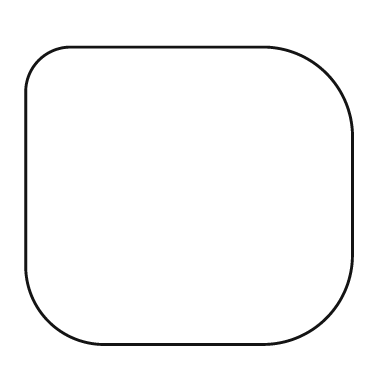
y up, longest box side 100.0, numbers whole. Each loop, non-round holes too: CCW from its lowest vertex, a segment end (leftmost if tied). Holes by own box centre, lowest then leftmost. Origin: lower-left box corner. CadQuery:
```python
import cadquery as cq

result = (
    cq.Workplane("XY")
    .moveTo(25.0, 0.0)
    .lineTo(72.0, 0.0)
    .threePointArc((92.0, 8.0), (100.0, 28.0))
    .lineTo(100.0, 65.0)
    .threePointArc((92.0, 83.0), (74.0, 91.0))
    .lineTo(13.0, 91.0)
    .threePointArc((4.0, 87.0), (0.0, 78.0))
    .lineTo(0.0, 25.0)
    .threePointArc((7.0, 7.0), (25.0, 0.0))
    .close()
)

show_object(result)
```